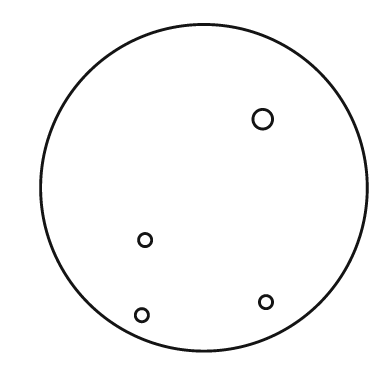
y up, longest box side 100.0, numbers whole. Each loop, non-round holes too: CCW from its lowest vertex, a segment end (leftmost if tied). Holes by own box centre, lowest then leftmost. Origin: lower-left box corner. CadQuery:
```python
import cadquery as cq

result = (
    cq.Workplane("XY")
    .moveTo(50.0, 50.0)
    .circle(50.0)
    .moveTo(31.0, 11.0)
    .circle(2.0)
    .moveTo(69.0, 15.0)
    .circle(2.0)
    .moveTo(32.0, 34.0)
    .circle(2.0)
    .moveTo(68.0, 71.0)
    .circle(3.0)
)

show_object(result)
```